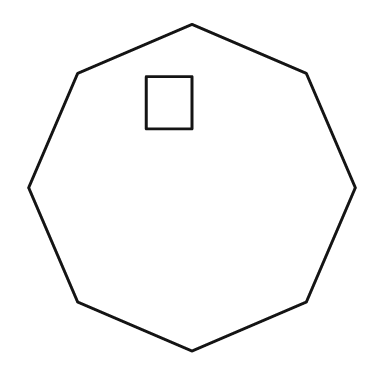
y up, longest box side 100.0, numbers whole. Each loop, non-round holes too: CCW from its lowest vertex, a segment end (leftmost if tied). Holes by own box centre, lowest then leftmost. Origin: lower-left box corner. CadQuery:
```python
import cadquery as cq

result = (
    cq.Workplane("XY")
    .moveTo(50.0, 0.0)
    .lineTo(85.0, 15.0)
    .lineTo(100.0, 50.0)
    .lineTo(85.0, 85.0)
    .lineTo(50.0, 100.0)
    .lineTo(15.0, 85.0)
    .lineTo(0.0, 50.0)
    .lineTo(15.0, 15.0)
    .close()
    .moveTo(36.0, 68.0)
    .lineTo(50.0, 68.0)
    .lineTo(50.0, 84.0)
    .lineTo(36.0, 84.0)
    .close()
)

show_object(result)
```